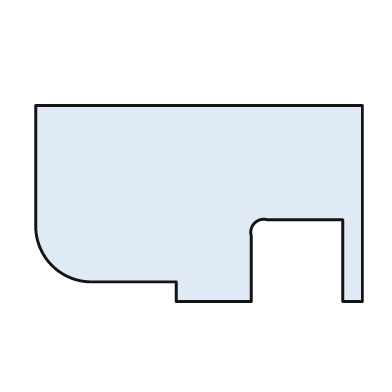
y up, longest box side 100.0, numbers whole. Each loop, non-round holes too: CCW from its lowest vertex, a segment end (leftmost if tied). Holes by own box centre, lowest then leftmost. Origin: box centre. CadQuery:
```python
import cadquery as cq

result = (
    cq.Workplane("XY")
    .moveTo(-7.0, -30.0)
    .lineTo(16.0, -30.0)
    .lineTo(16.0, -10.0)
    .threePointArc((17.0, -6.0), (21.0, -5.0))
    .lineTo(44.0, -5.0)
    .lineTo(44.0, -30.0)
    .lineTo(50.0, -30.0)
    .lineTo(50.0, 30.0)
    .lineTo(-50.0, 30.0)
    .lineTo(-50.0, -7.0)
    .threePointArc((-45.0, -19.0), (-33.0, -24.0))
    .lineTo(-7.0, -24.0)
    .close()
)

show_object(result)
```